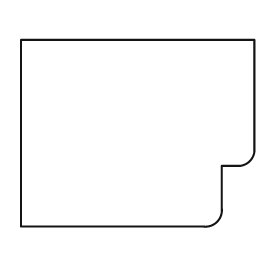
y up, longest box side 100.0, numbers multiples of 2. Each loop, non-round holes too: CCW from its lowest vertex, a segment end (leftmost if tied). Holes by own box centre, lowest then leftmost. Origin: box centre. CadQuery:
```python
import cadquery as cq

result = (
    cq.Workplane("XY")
    .moveTo(-50.0, -40.0)
    .lineTo(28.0, -40.0)
    .threePointArc((34.0, -38.0), (36.0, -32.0))
    .lineTo(36.0, -14.0)
    .lineTo(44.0, -14.0)
    .threePointArc((48.0, -12.0), (50.0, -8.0))
    .lineTo(50.0, 40.0)
    .lineTo(-50.0, 40.0)
    .close()
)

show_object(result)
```